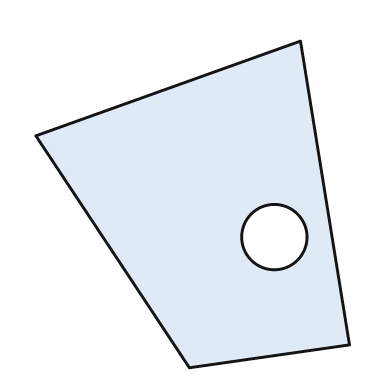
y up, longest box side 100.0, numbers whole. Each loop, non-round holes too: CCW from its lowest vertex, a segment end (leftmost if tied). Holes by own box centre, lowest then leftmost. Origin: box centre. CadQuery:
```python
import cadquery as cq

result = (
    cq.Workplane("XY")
    .moveTo(-1.0, -50.0)
    .lineTo(48.0, -43.0)
    .lineTo(33.0, 50.0)
    .lineTo(-48.0, 21.0)
    .close()
    .moveTo(25.0, -10.0)
    .circle(10.0)
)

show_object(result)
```